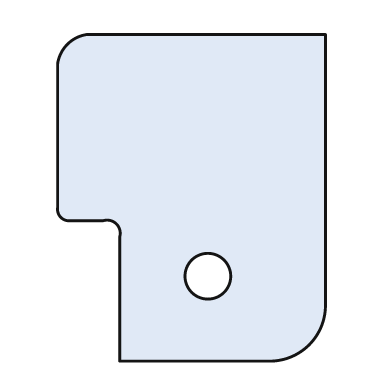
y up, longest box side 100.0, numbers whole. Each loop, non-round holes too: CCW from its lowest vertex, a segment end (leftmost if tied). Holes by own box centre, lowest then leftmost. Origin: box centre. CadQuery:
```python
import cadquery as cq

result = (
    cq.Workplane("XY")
    .moveTo(-22.0, -50.0)
    .lineTo(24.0, -50.0)
    .threePointArc((36.0, -45.0), (41.0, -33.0))
    .lineTo(41.0, 50.0)
    .lineTo(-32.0, 50.0)
    .threePointArc((-38.0, 47.0), (-41.0, 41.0))
    .lineTo(-41.0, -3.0)
    .threePointArc((-40.0, -6.0), (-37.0, -7.0))
    .lineTo(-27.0, -7.0)
    .threePointArc((-23.0, -8.0), (-22.0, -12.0))
    .close()
    .moveTo(5.0, -24.0)
    .circle(7.0)
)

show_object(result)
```